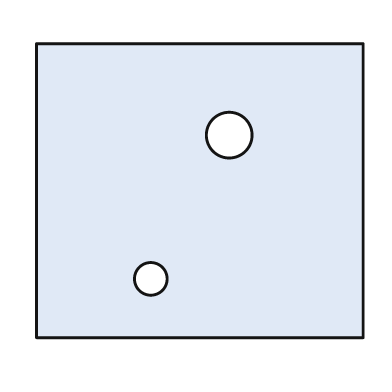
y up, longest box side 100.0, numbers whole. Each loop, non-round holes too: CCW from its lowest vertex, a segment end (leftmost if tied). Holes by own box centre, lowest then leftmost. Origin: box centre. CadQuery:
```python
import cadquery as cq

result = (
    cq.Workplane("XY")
    .moveTo(-50.0, -45.0)
    .lineTo(50.0, -45.0)
    .lineTo(50.0, 45.0)
    .lineTo(-50.0, 45.0)
    .close()
    .moveTo(-15.0, -27.0)
    .circle(5.0)
    .moveTo(9.0, 17.0)
    .circle(7.0)
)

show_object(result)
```